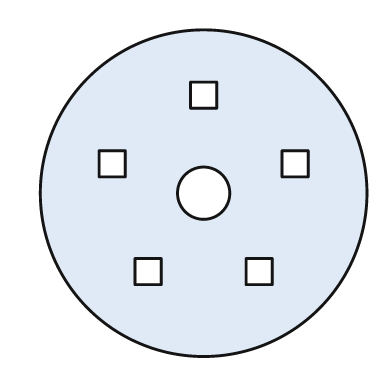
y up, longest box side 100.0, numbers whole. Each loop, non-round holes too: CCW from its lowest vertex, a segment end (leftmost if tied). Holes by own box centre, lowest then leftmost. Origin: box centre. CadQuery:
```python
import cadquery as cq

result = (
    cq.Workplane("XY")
    .moveTo(0.0, 0.0)
    .circle(50.0)
    .moveTo(-21.0, -28.0)
    .lineTo(-13.0, -28.0)
    .lineTo(-13.0, -20.0)
    .lineTo(-21.0, -20.0)
    .close()
    .moveTo(13.0, -28.0)
    .lineTo(21.0, -28.0)
    .lineTo(21.0, -20.0)
    .lineTo(13.0, -20.0)
    .close()
    .moveTo(0.0, 0.0)
    .circle(8.0)
    .moveTo(-32.0, 5.0)
    .lineTo(-24.0, 5.0)
    .lineTo(-24.0, 13.0)
    .lineTo(-32.0, 13.0)
    .close()
    .moveTo(24.0, 5.0)
    .lineTo(32.0, 5.0)
    .lineTo(32.0, 13.0)
    .lineTo(24.0, 13.0)
    .close()
    .moveTo(-4.0, 26.0)
    .lineTo(4.0, 26.0)
    .lineTo(4.0, 34.0)
    .lineTo(-4.0, 34.0)
    .close()
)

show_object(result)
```